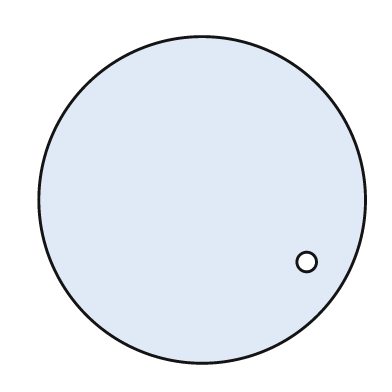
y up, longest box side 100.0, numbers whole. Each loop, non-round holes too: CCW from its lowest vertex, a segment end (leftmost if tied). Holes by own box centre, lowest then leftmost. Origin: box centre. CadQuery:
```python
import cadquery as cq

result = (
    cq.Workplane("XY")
    .moveTo(0.0, 0.0)
    .circle(50.0)
    .moveTo(32.0, -19.0)
    .circle(3.0)
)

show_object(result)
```